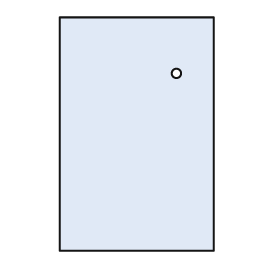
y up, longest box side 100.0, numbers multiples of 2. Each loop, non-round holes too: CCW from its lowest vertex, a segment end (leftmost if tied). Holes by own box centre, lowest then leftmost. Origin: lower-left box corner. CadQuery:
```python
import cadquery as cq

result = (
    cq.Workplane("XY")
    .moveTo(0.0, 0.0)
    .lineTo(66.0, 0.0)
    .lineTo(66.0, 100.0)
    .lineTo(0.0, 100.0)
    .close()
    .moveTo(50.0, 76.0)
    .circle(2.0)
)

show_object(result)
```